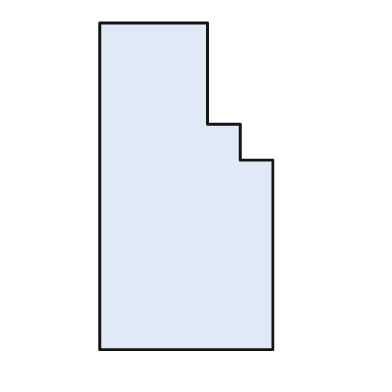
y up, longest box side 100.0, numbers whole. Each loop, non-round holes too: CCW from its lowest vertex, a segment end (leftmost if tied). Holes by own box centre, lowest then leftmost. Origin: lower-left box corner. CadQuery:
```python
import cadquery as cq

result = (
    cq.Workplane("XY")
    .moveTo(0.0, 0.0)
    .lineTo(53.0, 0.0)
    .lineTo(53.0, 58.0)
    .lineTo(43.0, 58.0)
    .lineTo(43.0, 69.0)
    .lineTo(33.0, 69.0)
    .lineTo(33.0, 100.0)
    .lineTo(0.0, 100.0)
    .close()
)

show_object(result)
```